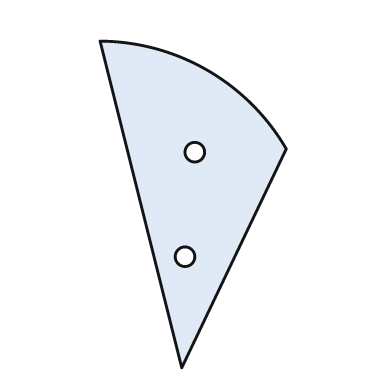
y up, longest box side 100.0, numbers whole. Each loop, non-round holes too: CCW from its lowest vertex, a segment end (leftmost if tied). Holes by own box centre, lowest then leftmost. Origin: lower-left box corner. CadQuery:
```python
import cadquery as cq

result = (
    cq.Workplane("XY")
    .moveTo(25.0, 0.0)
    .lineTo(57.0, 67.0)
    .threePointArc((33.0, 91.0), (0.0, 100.0))
    .close()
    .moveTo(26.0, 34.0)
    .circle(3.0)
    .moveTo(29.0, 66.0)
    .circle(3.0)
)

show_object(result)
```